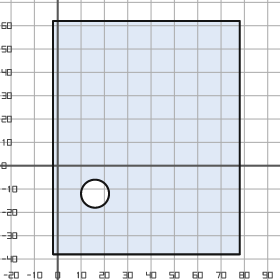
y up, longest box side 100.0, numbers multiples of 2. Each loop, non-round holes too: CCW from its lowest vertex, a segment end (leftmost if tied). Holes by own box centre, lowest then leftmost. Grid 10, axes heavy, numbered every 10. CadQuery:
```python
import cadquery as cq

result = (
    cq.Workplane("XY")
    .moveTo(-2.0, -38.0)
    .lineTo(78.0, -38.0)
    .lineTo(78.0, 62.0)
    .lineTo(-2.0, 62.0)
    .close()
    .moveTo(16.0, -12.0)
    .circle(6.0)
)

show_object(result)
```